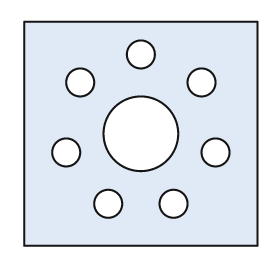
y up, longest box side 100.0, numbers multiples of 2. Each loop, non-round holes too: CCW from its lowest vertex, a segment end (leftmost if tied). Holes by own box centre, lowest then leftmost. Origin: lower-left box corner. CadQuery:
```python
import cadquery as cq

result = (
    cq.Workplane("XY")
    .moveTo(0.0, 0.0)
    .lineTo(100.0, 0.0)
    .lineTo(100.0, 96.0)
    .lineTo(0.0, 96.0)
    .close()
    .moveTo(36.0, 18.0)
    .circle(6.0)
    .moveTo(64.0, 18.0)
    .circle(6.0)
    .moveTo(18.0, 40.0)
    .circle(6.0)
    .moveTo(82.0, 40.0)
    .circle(6.0)
    .moveTo(50.0, 48.0)
    .circle(16.0)
    .moveTo(24.0, 70.0)
    .circle(6.0)
    .moveTo(76.0, 70.0)
    .circle(6.0)
    .moveTo(50.0, 82.0)
    .circle(6.0)
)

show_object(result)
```